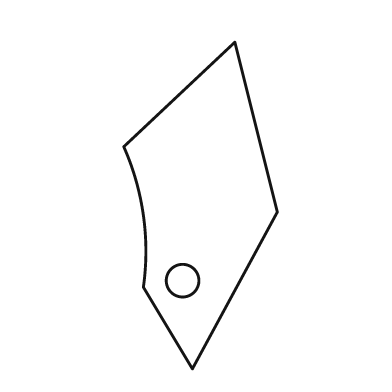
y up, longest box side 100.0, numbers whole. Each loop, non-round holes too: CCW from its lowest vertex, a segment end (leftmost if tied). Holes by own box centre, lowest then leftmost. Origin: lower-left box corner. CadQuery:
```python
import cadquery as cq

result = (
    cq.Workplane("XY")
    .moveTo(21.0, 0.0)
    .lineTo(47.0, 48.0)
    .lineTo(34.0, 100.0)
    .lineTo(0.0, 68.0)
    .threePointArc((6.0, 47.0), (6.0, 25.0))
    .close()
    .moveTo(18.0, 27.0)
    .circle(5.0)
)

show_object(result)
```